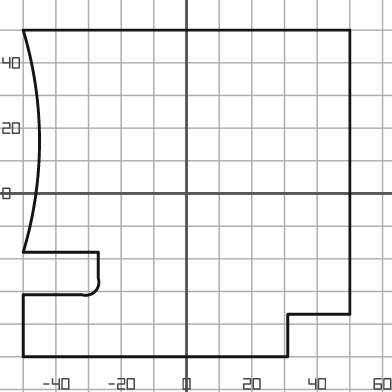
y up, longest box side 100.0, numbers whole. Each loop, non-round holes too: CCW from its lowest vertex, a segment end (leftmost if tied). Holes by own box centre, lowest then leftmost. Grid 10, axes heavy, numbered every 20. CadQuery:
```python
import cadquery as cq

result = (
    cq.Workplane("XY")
    .moveTo(-50.0, -50.0)
    .lineTo(31.0, -50.0)
    .lineTo(31.0, -37.0)
    .lineTo(50.0, -37.0)
    .lineTo(50.0, 50.0)
    .lineTo(-50.0, 50.0)
    .threePointArc((-45.0, 16.0), (-50.0, -18.0))
    .lineTo(-27.0, -18.0)
    .lineTo(-27.0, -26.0)
    .threePointArc((-28.0, -30.0), (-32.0, -31.0))
    .lineTo(-50.0, -31.0)
    .close()
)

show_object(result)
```